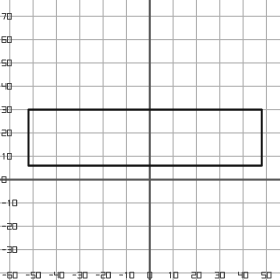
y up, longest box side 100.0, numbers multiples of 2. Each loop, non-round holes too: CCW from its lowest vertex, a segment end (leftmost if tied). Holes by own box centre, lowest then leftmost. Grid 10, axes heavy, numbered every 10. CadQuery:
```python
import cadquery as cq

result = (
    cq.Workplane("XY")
    .moveTo(-52.0, 6.0)
    .lineTo(48.0, 6.0)
    .lineTo(48.0, 30.0)
    .lineTo(-52.0, 30.0)
    .close()
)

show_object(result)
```